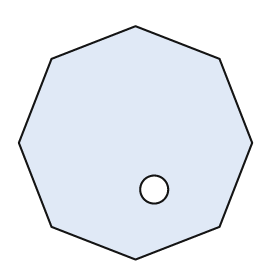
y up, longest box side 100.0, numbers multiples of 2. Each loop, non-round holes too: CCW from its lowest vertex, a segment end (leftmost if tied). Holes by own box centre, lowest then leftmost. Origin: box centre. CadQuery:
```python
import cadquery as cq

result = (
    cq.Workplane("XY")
    .moveTo(0.0, -50.0)
    .lineTo(36.0, -36.0)
    .lineTo(50.0, 0.0)
    .lineTo(36.0, 36.0)
    .lineTo(0.0, 50.0)
    .lineTo(-36.0, 36.0)
    .lineTo(-50.0, 0.0)
    .lineTo(-36.0, -36.0)
    .close()
    .moveTo(8.0, -20.0)
    .circle(6.0)
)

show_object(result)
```